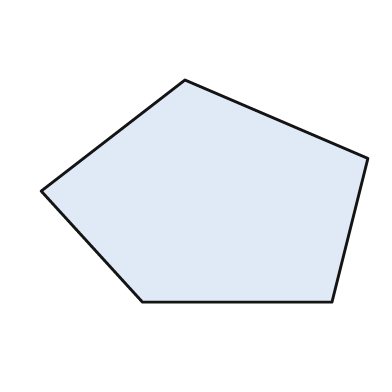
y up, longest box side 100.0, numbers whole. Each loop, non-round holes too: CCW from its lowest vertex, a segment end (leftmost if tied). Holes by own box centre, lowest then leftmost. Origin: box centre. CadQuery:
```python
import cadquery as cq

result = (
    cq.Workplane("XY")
    .moveTo(-19.0, -34.0)
    .lineTo(39.0, -34.0)
    .lineTo(50.0, 10.0)
    .lineTo(-6.0, 34.0)
    .lineTo(-50.0, 0.0)
    .close()
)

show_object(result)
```